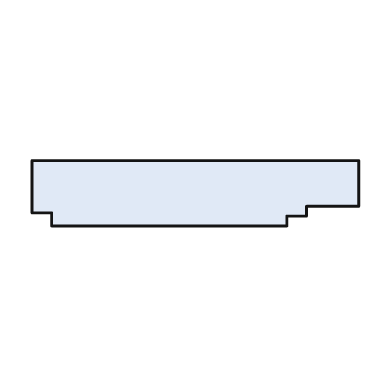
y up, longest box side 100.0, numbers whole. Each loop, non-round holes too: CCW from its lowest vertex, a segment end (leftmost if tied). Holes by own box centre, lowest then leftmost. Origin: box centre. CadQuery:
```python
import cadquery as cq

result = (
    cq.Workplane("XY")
    .moveTo(-44.0, -10.0)
    .lineTo(28.0, -10.0)
    .lineTo(28.0, -7.0)
    .lineTo(34.0, -7.0)
    .lineTo(34.0, -4.0)
    .lineTo(50.0, -4.0)
    .lineTo(50.0, 10.0)
    .lineTo(-50.0, 10.0)
    .lineTo(-50.0, -6.0)
    .lineTo(-44.0, -6.0)
    .close()
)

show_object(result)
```